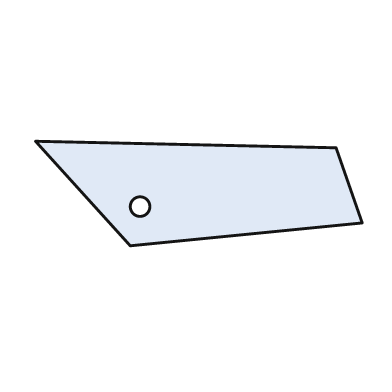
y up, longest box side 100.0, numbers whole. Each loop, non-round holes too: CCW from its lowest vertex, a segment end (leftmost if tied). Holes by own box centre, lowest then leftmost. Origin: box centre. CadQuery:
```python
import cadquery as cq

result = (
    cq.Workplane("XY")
    .moveTo(-21.0, -16.0)
    .lineTo(50.0, -9.0)
    .lineTo(42.0, 14.0)
    .lineTo(-50.0, 16.0)
    .close()
    .moveTo(-18.0, -4.0)
    .circle(3.0)
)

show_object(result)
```